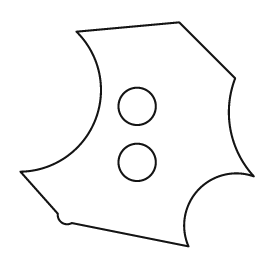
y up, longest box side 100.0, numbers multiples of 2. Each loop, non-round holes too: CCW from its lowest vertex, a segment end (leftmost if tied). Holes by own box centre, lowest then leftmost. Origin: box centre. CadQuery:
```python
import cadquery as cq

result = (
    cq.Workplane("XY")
    .moveTo(22.0, -48.0)
    .threePointArc((26.0, -24.0), (50.0, -18.0))
    .threePointArc((40.0, 2.0), (42.0, 24.0))
    .lineTo(18.0, 48.0)
    .lineTo(-26.0, 44.0)
    .threePointArc((-18.0, 6.0), (-50.0, -16.0))
    .lineTo(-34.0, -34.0)
    .threePointArc((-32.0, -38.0), (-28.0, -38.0))
    .close()
    .moveTo(0.0, -12.0)
    .circle(8.0)
    .moveTo(0.0, 12.0)
    .circle(8.0)
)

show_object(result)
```